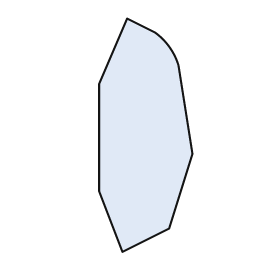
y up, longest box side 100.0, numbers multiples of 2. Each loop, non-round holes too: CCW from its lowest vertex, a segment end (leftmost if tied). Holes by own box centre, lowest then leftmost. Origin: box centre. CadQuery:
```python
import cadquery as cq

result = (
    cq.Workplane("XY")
    .moveTo(-10.0, -50.0)
    .lineTo(10.0, -40.0)
    .lineTo(20.0, -8.0)
    .lineTo(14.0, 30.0)
    .threePointArc((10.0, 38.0), (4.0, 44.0))
    .lineTo(-8.0, 50.0)
    .lineTo(-20.0, 22.0)
    .lineTo(-20.0, -24.0)
    .close()
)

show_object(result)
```